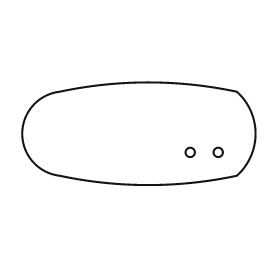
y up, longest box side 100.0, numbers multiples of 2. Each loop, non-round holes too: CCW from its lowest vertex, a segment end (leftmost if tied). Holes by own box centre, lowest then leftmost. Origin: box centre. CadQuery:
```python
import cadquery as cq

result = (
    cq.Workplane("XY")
    .moveTo(-34.0, -18.0)
    .threePointArc((4.0, -22.0), (42.0, -18.0))
    .threePointArc((50.0, 0.0), (42.0, 18.0))
    .threePointArc((4.0, 22.0), (-34.0, 18.0))
    .threePointArc((-50.0, 0.0), (-34.0, -18.0))
    .close()
    .moveTo(22.0, -8.0)
    .circle(2.0)
    .moveTo(34.0, -8.0)
    .circle(2.0)
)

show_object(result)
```